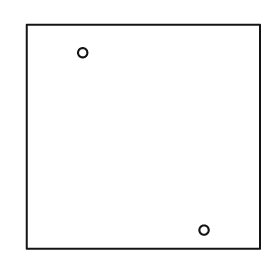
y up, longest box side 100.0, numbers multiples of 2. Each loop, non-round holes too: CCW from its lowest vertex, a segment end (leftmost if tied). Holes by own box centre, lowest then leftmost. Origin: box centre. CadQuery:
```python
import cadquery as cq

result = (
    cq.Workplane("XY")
    .moveTo(-50.0, -48.0)
    .lineTo(50.0, -48.0)
    .lineTo(50.0, 48.0)
    .lineTo(-50.0, 48.0)
    .close()
    .moveTo(26.0, -40.0)
    .circle(2.0)
    .moveTo(-26.0, 36.0)
    .circle(2.0)
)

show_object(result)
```